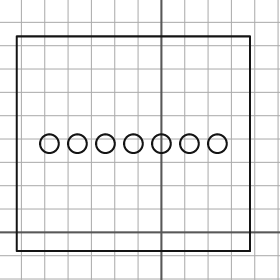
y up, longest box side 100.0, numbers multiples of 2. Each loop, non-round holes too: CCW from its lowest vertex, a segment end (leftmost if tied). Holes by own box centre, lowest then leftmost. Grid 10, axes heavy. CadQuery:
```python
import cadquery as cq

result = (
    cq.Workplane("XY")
    .moveTo(-62.0, -8.0)
    .lineTo(38.0, -8.0)
    .lineTo(38.0, 84.0)
    .lineTo(-62.0, 84.0)
    .close()
    .moveTo(-48.0, 38.0)
    .circle(4.0)
    .moveTo(-36.0, 38.0)
    .circle(4.0)
    .moveTo(-24.0, 38.0)
    .circle(4.0)
    .moveTo(-12.0, 38.0)
    .circle(4.0)
    .moveTo(0.0, 38.0)
    .circle(4.0)
    .moveTo(12.0, 38.0)
    .circle(4.0)
    .moveTo(24.0, 38.0)
    .circle(4.0)
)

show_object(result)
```